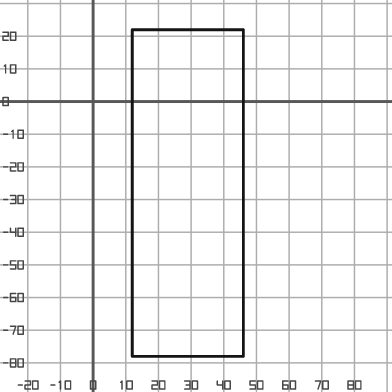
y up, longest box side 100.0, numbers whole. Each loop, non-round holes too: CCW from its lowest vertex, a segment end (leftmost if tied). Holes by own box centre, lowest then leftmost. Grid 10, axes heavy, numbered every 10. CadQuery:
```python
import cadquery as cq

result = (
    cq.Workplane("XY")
    .moveTo(12.0, -78.0)
    .lineTo(46.0, -78.0)
    .lineTo(46.0, 22.0)
    .lineTo(12.0, 22.0)
    .close()
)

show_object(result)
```